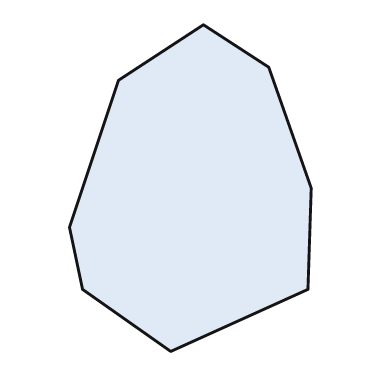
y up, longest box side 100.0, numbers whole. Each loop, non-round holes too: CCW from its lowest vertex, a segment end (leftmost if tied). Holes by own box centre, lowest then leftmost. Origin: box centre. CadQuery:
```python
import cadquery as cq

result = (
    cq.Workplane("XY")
    .moveTo(-6.0, -50.0)
    .lineTo(36.0, -31.0)
    .lineTo(37.0, 0.0)
    .lineTo(24.0, 37.0)
    .lineTo(4.0, 50.0)
    .lineTo(-22.0, 33.0)
    .lineTo(-37.0, -12.0)
    .lineTo(-33.0, -31.0)
    .close()
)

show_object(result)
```